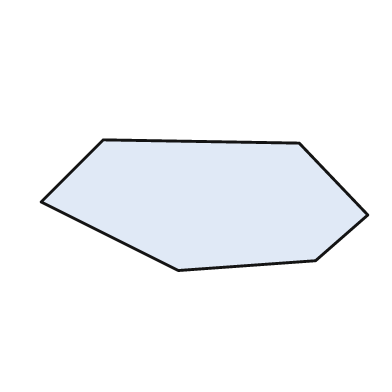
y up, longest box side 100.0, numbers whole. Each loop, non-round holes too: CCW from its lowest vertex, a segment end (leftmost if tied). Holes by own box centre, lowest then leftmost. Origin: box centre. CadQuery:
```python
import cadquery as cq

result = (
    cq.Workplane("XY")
    .moveTo(-8.0, -20.0)
    .lineTo(34.0, -17.0)
    .lineTo(50.0, -3.0)
    .lineTo(29.0, 19.0)
    .lineTo(-31.0, 20.0)
    .lineTo(-50.0, 1.0)
    .close()
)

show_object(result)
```